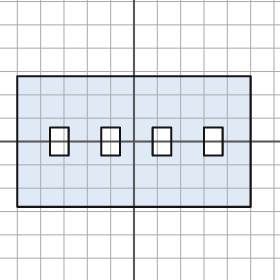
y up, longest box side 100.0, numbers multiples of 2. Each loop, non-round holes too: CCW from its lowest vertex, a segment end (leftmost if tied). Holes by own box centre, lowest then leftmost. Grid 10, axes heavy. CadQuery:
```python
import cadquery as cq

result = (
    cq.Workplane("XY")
    .moveTo(-50.0, -28.0)
    .lineTo(50.0, -28.0)
    .lineTo(50.0, 28.0)
    .lineTo(-50.0, 28.0)
    .close()
    .moveTo(-36.0, -6.0)
    .lineTo(-28.0, -6.0)
    .lineTo(-28.0, 6.0)
    .lineTo(-36.0, 6.0)
    .close()
    .moveTo(-14.0, -6.0)
    .lineTo(-6.0, -6.0)
    .lineTo(-6.0, 6.0)
    .lineTo(-14.0, 6.0)
    .close()
    .moveTo(8.0, -6.0)
    .lineTo(16.0, -6.0)
    .lineTo(16.0, 6.0)
    .lineTo(8.0, 6.0)
    .close()
    .moveTo(30.0, -6.0)
    .lineTo(38.0, -6.0)
    .lineTo(38.0, 6.0)
    .lineTo(30.0, 6.0)
    .close()
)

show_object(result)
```